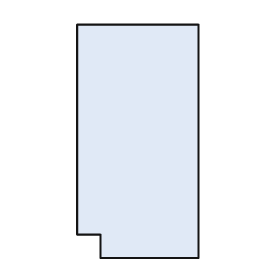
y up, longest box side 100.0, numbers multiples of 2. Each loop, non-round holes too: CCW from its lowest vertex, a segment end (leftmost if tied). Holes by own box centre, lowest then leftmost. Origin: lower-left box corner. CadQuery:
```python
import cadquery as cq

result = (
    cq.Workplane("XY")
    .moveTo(10.0, 0.0)
    .lineTo(52.0, 0.0)
    .lineTo(52.0, 100.0)
    .lineTo(0.0, 100.0)
    .lineTo(0.0, 10.0)
    .lineTo(10.0, 10.0)
    .close()
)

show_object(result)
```